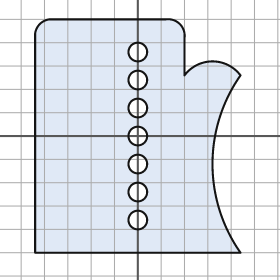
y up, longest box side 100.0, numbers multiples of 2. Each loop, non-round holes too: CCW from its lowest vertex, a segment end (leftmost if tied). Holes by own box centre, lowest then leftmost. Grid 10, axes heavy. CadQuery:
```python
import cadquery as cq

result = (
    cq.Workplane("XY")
    .moveTo(-44.0, -50.0)
    .lineTo(44.0, -50.0)
    .threePointArc((32.0, -12.0), (44.0, 26.0))
    .threePointArc((32.0, 32.0), (20.0, 26.0))
    .lineTo(20.0, 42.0)
    .threePointArc((18.0, 48.0), (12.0, 50.0))
    .lineTo(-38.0, 50.0)
    .threePointArc((-42.0, 48.0), (-44.0, 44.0))
    .close()
    .moveTo(0.0, -36.0)
    .circle(4.0)
    .moveTo(0.0, -24.0)
    .circle(4.0)
    .moveTo(0.0, -12.0)
    .circle(4.0)
    .moveTo(0.0, 0.0)
    .circle(4.0)
    .moveTo(0.0, 12.0)
    .circle(4.0)
    .moveTo(0.0, 24.0)
    .circle(4.0)
    .moveTo(0.0, 36.0)
    .circle(4.0)
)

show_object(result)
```